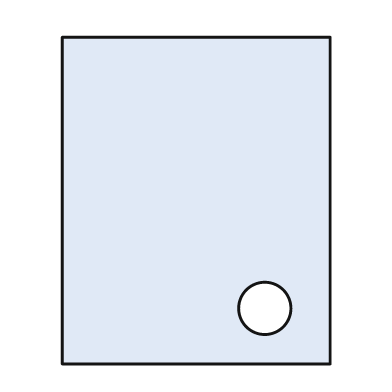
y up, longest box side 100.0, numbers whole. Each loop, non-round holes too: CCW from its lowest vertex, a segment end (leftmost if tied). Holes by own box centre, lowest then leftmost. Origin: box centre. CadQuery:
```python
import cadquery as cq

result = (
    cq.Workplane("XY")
    .moveTo(-41.0, -50.0)
    .lineTo(41.0, -50.0)
    .lineTo(41.0, 50.0)
    .lineTo(-41.0, 50.0)
    .close()
    .moveTo(21.0, -33.0)
    .circle(8.0)
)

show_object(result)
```